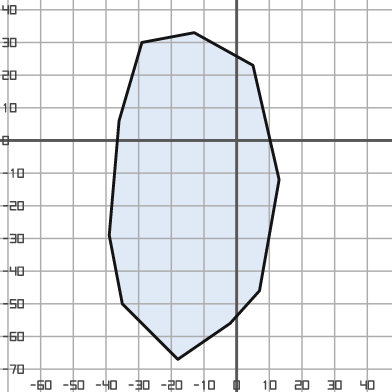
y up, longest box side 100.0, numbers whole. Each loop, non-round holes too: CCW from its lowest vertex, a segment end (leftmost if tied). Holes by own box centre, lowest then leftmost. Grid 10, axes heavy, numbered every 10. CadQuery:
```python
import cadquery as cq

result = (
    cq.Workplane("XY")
    .moveTo(-18.0, -67.0)
    .lineTo(-2.0, -56.0)
    .lineTo(7.0, -46.0)
    .lineTo(13.0, -12.0)
    .lineTo(5.0, 23.0)
    .lineTo(-13.0, 33.0)
    .lineTo(-29.0, 30.0)
    .lineTo(-36.0, 6.0)
    .lineTo(-39.0, -29.0)
    .lineTo(-35.0, -50.0)
    .close()
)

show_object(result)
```